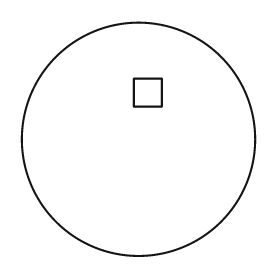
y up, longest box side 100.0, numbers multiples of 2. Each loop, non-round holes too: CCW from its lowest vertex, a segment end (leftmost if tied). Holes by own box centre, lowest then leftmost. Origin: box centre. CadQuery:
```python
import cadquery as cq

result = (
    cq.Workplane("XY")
    .moveTo(0.0, 0.0)
    .circle(50.0)
    .moveTo(-2.0, 14.0)
    .lineTo(10.0, 14.0)
    .lineTo(10.0, 26.0)
    .lineTo(-2.0, 26.0)
    .close()
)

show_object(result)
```